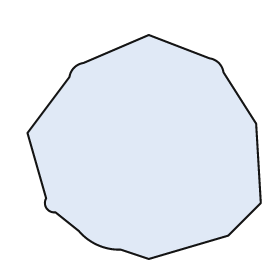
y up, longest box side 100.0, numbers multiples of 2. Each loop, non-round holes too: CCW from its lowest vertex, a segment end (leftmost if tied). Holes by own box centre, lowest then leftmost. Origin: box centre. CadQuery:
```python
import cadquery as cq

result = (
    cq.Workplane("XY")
    .moveTo(2.0, -48.0)
    .lineTo(36.0, -38.0)
    .lineTo(50.0, -24.0)
    .lineTo(48.0, 10.0)
    .lineTo(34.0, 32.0)
    .threePointArc((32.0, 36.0), (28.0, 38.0))
    .lineTo(2.0, 48.0)
    .lineTo(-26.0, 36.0)
    .threePointArc((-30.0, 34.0), (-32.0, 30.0))
    .lineTo(-50.0, 6.0)
    .lineTo(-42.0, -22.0)
    .threePointArc((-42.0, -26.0), (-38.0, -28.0))
    .lineTo(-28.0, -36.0)
    .threePointArc((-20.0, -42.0), (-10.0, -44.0))
    .close()
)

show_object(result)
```